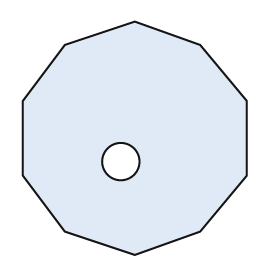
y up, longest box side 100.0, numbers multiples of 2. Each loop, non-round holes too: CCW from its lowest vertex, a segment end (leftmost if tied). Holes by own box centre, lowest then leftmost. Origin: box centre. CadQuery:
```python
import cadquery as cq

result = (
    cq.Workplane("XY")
    .moveTo(0.0, -50.0)
    .lineTo(28.0, -40.0)
    .lineTo(48.0, -16.0)
    .lineTo(48.0, 16.0)
    .lineTo(28.0, 40.0)
    .lineTo(0.0, 50.0)
    .lineTo(-30.0, 40.0)
    .lineTo(-48.0, 16.0)
    .lineTo(-48.0, -16.0)
    .lineTo(-30.0, -40.0)
    .close()
    .moveTo(-6.0, -10.0)
    .circle(8.0)
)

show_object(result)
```